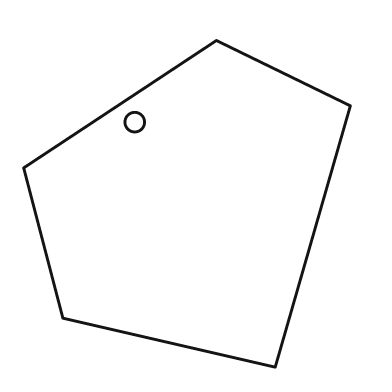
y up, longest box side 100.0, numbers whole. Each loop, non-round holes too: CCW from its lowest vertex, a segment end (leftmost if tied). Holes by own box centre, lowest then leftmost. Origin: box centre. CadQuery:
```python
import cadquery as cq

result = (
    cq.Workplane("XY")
    .moveTo(27.0, -50.0)
    .lineTo(50.0, 30.0)
    .lineTo(9.0, 50.0)
    .lineTo(-50.0, 11.0)
    .lineTo(-38.0, -35.0)
    .close()
    .moveTo(-16.0, 25.0)
    .circle(3.0)
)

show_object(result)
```